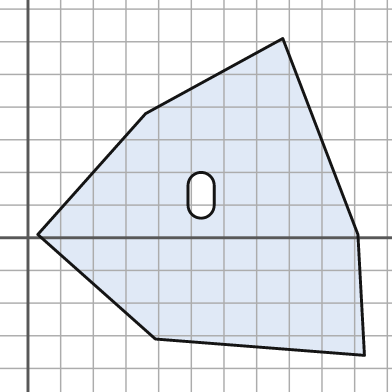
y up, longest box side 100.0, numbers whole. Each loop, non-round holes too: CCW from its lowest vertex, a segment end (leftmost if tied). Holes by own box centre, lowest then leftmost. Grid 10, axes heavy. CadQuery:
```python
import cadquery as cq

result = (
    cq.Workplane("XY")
    .moveTo(103.0, -36.0)
    .lineTo(101.0, 1.0)
    .lineTo(78.0, 61.0)
    .lineTo(36.0, 38.0)
    .lineTo(3.0, 1.0)
    .lineTo(39.0, -31.0)
    .close()
    .moveTo(49.0, 10.0)
    .threePointArc((53.0, 6.0), (57.0, 10.0))
    .lineTo(57.0, 16.0)
    .threePointArc((53.0, 20.0), (49.0, 16.0))
    .close()
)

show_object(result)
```